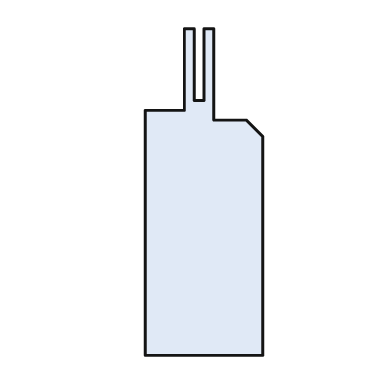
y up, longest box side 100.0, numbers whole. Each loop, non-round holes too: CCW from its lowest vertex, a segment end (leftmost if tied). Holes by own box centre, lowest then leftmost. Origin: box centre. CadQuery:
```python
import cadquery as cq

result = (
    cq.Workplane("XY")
    .moveTo(-18.0, -50.0)
    .lineTo(18.0, -50.0)
    .lineTo(18.0, 17.0)
    .lineTo(13.0, 22.0)
    .lineTo(3.0, 22.0)
    .lineTo(3.0, 50.0)
    .lineTo(0.0, 50.0)
    .lineTo(0.0, 28.0)
    .lineTo(-3.0, 28.0)
    .lineTo(-3.0, 50.0)
    .lineTo(-6.0, 50.0)
    .lineTo(-6.0, 25.0)
    .lineTo(-18.0, 25.0)
    .close()
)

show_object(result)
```